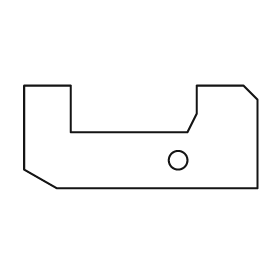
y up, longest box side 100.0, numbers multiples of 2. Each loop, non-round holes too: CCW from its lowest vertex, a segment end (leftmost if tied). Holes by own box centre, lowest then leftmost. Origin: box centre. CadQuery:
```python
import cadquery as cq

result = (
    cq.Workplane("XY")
    .moveTo(-36.0, -22.0)
    .lineTo(50.0, -22.0)
    .lineTo(50.0, 16.0)
    .lineTo(44.0, 22.0)
    .lineTo(24.0, 22.0)
    .lineTo(24.0, 10.0)
    .lineTo(20.0, 2.0)
    .lineTo(-30.0, 2.0)
    .lineTo(-30.0, 22.0)
    .lineTo(-50.0, 22.0)
    .lineTo(-50.0, -14.0)
    .close()
    .moveTo(16.0, -10.0)
    .circle(4.0)
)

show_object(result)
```